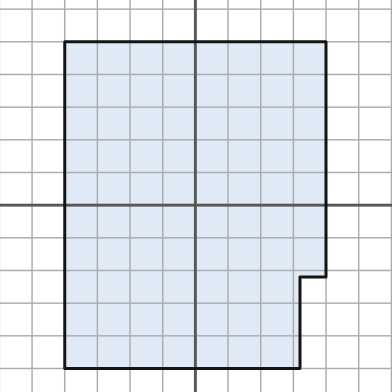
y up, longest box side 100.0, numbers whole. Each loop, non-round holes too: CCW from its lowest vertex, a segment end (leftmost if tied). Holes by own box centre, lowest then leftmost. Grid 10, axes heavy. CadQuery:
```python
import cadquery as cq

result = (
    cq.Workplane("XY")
    .moveTo(-40.0, -50.0)
    .lineTo(32.0, -50.0)
    .lineTo(32.0, -22.0)
    .lineTo(40.0, -22.0)
    .lineTo(40.0, 50.0)
    .lineTo(-40.0, 50.0)
    .close()
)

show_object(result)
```